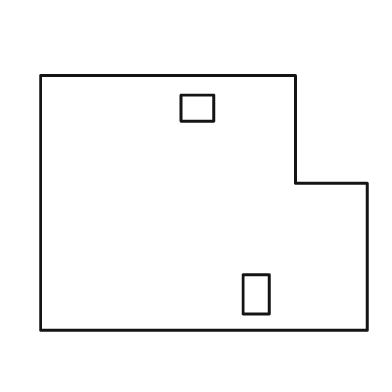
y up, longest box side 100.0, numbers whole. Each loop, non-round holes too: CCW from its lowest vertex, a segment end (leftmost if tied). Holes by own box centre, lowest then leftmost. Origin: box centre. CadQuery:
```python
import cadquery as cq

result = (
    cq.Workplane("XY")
    .moveTo(-50.0, -39.0)
    .lineTo(50.0, -39.0)
    .lineTo(50.0, 6.0)
    .lineTo(28.0, 6.0)
    .lineTo(28.0, 39.0)
    .lineTo(-50.0, 39.0)
    .close()
    .moveTo(12.0, -34.0)
    .lineTo(20.0, -34.0)
    .lineTo(20.0, -22.0)
    .lineTo(12.0, -22.0)
    .close()
    .moveTo(-7.0, 25.0)
    .lineTo(3.0, 25.0)
    .lineTo(3.0, 33.0)
    .lineTo(-7.0, 33.0)
    .close()
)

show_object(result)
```